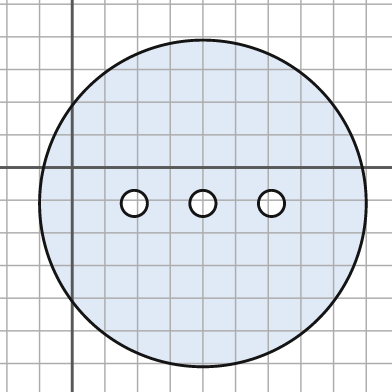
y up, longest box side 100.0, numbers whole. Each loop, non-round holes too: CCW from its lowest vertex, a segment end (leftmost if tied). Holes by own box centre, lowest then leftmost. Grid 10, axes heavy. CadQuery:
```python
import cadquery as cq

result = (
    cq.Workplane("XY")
    .moveTo(40.0, -11.0)
    .circle(50.0)
    .moveTo(19.0, -11.0)
    .circle(4.0)
    .moveTo(40.0, -11.0)
    .circle(4.0)
    .moveTo(61.0, -11.0)
    .circle(4.0)
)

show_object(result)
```